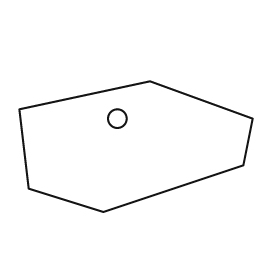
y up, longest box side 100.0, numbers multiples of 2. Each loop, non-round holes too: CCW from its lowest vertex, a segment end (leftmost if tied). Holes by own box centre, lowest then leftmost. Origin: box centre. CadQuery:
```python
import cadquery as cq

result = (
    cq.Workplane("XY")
    .moveTo(-14.0, -28.0)
    .lineTo(46.0, -8.0)
    .lineTo(50.0, 12.0)
    .lineTo(6.0, 28.0)
    .lineTo(-50.0, 16.0)
    .lineTo(-46.0, -18.0)
    .close()
    .moveTo(-8.0, 12.0)
    .circle(4.0)
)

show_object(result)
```